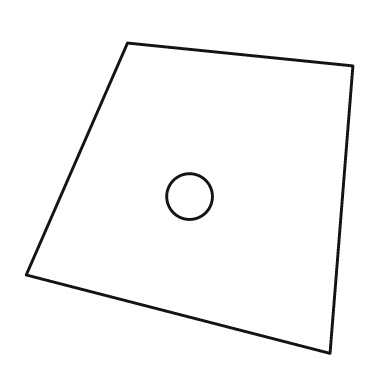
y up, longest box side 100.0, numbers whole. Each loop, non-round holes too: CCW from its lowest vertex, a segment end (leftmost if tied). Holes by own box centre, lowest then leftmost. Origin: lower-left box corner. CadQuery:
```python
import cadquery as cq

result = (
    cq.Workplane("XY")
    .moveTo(93.0, 0.0)
    .lineTo(100.0, 88.0)
    .lineTo(31.0, 95.0)
    .lineTo(0.0, 24.0)
    .close()
    .moveTo(50.0, 48.0)
    .circle(7.0)
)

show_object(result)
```